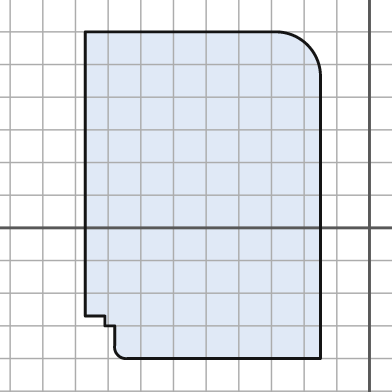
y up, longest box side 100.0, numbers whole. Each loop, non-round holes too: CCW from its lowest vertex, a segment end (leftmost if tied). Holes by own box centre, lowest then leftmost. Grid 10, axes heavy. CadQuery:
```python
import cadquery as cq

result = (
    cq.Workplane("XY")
    .moveTo(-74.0, -40.0)
    .lineTo(-15.0, -40.0)
    .lineTo(-15.0, 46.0)
    .threePointArc((-19.0, 56.0), (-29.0, 60.0))
    .lineTo(-87.0, 60.0)
    .lineTo(-87.0, -27.0)
    .lineTo(-81.0, -27.0)
    .lineTo(-81.0, -30.0)
    .lineTo(-78.0, -30.0)
    .lineTo(-78.0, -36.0)
    .threePointArc((-77.0, -39.0), (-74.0, -40.0))
    .close()
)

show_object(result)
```